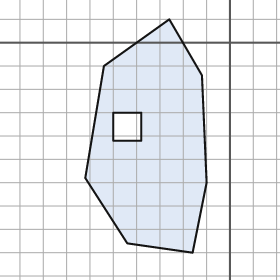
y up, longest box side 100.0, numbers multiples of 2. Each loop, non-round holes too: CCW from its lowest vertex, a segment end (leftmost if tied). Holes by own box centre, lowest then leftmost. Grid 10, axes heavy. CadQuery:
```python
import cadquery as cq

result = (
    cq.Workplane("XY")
    .moveTo(-16.0, -90.0)
    .lineTo(-10.0, -60.0)
    .lineTo(-12.0, -14.0)
    .lineTo(-26.0, 10.0)
    .lineTo(-54.0, -10.0)
    .lineTo(-62.0, -58.0)
    .lineTo(-44.0, -86.0)
    .close()
    .moveTo(-50.0, -42.0)
    .lineTo(-38.0, -42.0)
    .lineTo(-38.0, -30.0)
    .lineTo(-50.0, -30.0)
    .close()
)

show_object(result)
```